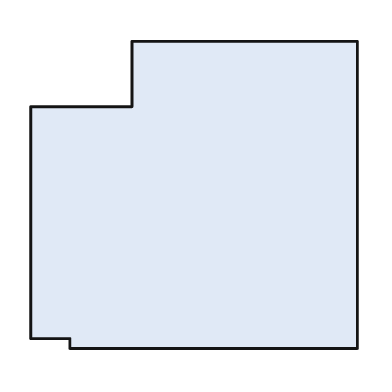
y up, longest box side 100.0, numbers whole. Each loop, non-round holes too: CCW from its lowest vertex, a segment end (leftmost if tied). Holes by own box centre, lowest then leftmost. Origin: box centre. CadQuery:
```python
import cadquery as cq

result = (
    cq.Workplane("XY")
    .moveTo(-38.0, -47.0)
    .lineTo(50.0, -47.0)
    .lineTo(50.0, 47.0)
    .lineTo(-19.0, 47.0)
    .lineTo(-19.0, 27.0)
    .lineTo(-50.0, 27.0)
    .lineTo(-50.0, -44.0)
    .lineTo(-38.0, -44.0)
    .close()
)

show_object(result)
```